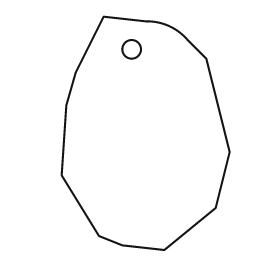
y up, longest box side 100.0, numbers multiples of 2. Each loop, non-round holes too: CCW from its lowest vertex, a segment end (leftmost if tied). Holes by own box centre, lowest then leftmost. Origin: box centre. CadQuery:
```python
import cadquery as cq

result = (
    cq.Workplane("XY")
    .moveTo(8.0, -50.0)
    .lineTo(30.0, -32.0)
    .lineTo(36.0, -8.0)
    .lineTo(26.0, 32.0)
    .lineTo(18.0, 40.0)
    .threePointArc((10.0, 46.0), (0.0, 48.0))
    .lineTo(-18.0, 50.0)
    .lineTo(-30.0, 26.0)
    .lineTo(-34.0, 12.0)
    .lineTo(-36.0, -18.0)
    .lineTo(-20.0, -44.0)
    .lineTo(-10.0, -48.0)
    .close()
    .moveTo(-6.0, 36.0)
    .circle(4.0)
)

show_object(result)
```